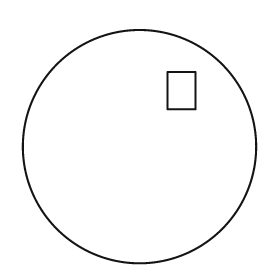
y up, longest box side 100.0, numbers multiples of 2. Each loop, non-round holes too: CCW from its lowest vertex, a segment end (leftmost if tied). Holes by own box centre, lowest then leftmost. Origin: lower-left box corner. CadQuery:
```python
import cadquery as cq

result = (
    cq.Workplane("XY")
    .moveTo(50.0, 50.0)
    .circle(50.0)
    .moveTo(62.0, 66.0)
    .lineTo(74.0, 66.0)
    .lineTo(74.0, 82.0)
    .lineTo(62.0, 82.0)
    .close()
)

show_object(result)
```